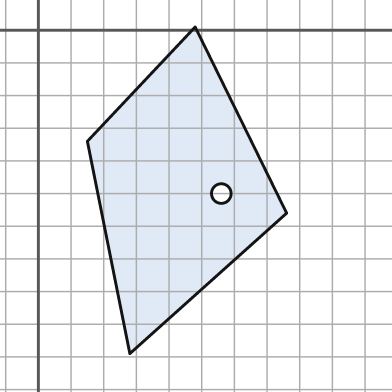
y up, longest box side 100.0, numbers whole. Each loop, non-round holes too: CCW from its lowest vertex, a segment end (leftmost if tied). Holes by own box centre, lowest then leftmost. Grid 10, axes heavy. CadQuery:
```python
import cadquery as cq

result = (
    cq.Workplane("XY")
    .moveTo(28.0, -99.0)
    .lineTo(76.0, -56.0)
    .lineTo(48.0, 1.0)
    .lineTo(15.0, -34.0)
    .close()
    .moveTo(56.0, -50.0)
    .circle(3.0)
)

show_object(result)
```